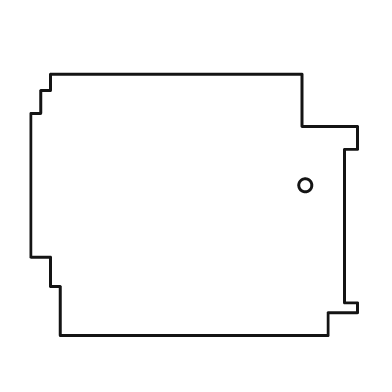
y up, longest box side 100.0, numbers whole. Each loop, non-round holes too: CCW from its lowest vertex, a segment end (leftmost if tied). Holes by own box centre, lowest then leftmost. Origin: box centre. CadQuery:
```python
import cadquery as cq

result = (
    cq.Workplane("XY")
    .moveTo(-41.0, -40.0)
    .lineTo(41.0, -40.0)
    .lineTo(41.0, -33.0)
    .lineTo(50.0, -33.0)
    .lineTo(50.0, -30.0)
    .lineTo(46.0, -30.0)
    .lineTo(46.0, 17.0)
    .lineTo(50.0, 17.0)
    .lineTo(50.0, 24.0)
    .lineTo(33.0, 24.0)
    .lineTo(33.0, 40.0)
    .lineTo(-44.0, 40.0)
    .lineTo(-44.0, 35.0)
    .lineTo(-47.0, 35.0)
    .lineTo(-47.0, 28.0)
    .lineTo(-50.0, 28.0)
    .lineTo(-50.0, -16.0)
    .lineTo(-44.0, -16.0)
    .lineTo(-44.0, -25.0)
    .lineTo(-41.0, -25.0)
    .close()
    .moveTo(34.0, 6.0)
    .circle(2.0)
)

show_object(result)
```